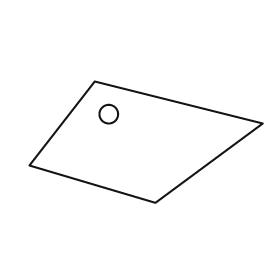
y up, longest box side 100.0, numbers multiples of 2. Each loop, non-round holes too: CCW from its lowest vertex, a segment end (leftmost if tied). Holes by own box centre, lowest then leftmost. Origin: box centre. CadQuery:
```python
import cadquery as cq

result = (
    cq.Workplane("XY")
    .moveTo(4.0, -26.0)
    .lineTo(50.0, 8.0)
    .lineTo(-22.0, 26.0)
    .lineTo(-50.0, -10.0)
    .close()
    .moveTo(-16.0, 12.0)
    .circle(4.0)
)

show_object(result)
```